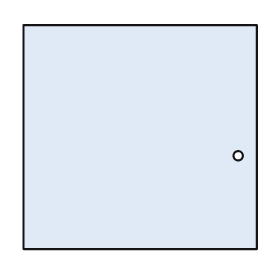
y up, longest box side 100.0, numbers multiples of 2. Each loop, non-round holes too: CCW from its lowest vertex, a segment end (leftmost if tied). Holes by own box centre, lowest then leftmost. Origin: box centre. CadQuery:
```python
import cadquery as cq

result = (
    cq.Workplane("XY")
    .moveTo(-50.0, -48.0)
    .lineTo(50.0, -48.0)
    .lineTo(50.0, 48.0)
    .lineTo(-50.0, 48.0)
    .close()
    .moveTo(42.0, -8.0)
    .circle(2.0)
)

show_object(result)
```